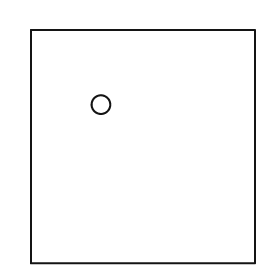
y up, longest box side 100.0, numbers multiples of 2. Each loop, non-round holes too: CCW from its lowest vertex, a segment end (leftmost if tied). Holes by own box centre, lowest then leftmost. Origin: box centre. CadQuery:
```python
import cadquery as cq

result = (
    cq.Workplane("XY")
    .moveTo(-48.0, -50.0)
    .lineTo(48.0, -50.0)
    .lineTo(48.0, 50.0)
    .lineTo(-48.0, 50.0)
    .close()
    .moveTo(-18.0, 18.0)
    .circle(4.0)
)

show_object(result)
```